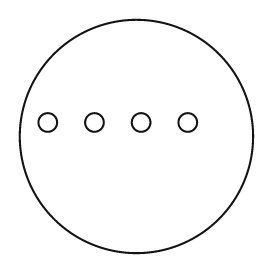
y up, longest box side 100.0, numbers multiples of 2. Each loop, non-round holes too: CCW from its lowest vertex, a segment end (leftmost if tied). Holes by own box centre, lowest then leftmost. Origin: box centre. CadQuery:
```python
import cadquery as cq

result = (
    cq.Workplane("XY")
    .moveTo(0.0, 0.0)
    .circle(50.0)
    .moveTo(-38.0, 6.0)
    .circle(4.0)
    .moveTo(-18.0, 6.0)
    .circle(4.0)
    .moveTo(2.0, 6.0)
    .circle(4.0)
    .moveTo(22.0, 6.0)
    .circle(4.0)
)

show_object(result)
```